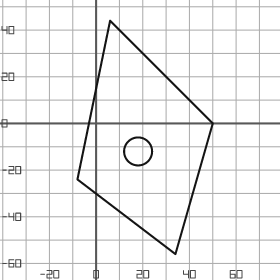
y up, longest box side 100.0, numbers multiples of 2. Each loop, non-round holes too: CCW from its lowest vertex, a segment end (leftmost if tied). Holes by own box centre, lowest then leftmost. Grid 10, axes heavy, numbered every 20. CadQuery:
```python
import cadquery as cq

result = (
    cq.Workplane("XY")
    .moveTo(34.0, -56.0)
    .lineTo(50.0, 0.0)
    .lineTo(6.0, 44.0)
    .lineTo(-8.0, -24.0)
    .close()
    .moveTo(18.0, -12.0)
    .circle(6.0)
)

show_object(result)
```